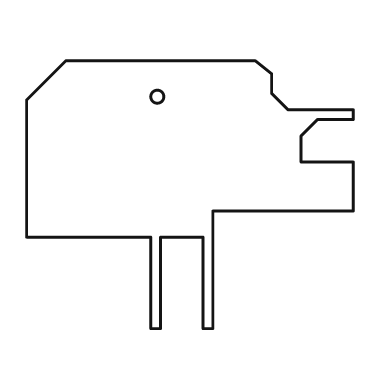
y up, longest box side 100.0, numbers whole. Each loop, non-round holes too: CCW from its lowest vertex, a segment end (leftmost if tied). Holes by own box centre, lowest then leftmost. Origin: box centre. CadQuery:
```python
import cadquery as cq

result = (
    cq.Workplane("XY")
    .moveTo(-12.0, -41.0)
    .lineTo(-9.0, -41.0)
    .lineTo(-9.0, -13.0)
    .lineTo(4.0, -13.0)
    .lineTo(4.0, -41.0)
    .lineTo(7.0, -41.0)
    .lineTo(7.0, -5.0)
    .lineTo(50.0, -5.0)
    .lineTo(50.0, 10.0)
    .lineTo(34.0, 10.0)
    .lineTo(34.0, 18.0)
    .lineTo(39.0, 23.0)
    .lineTo(50.0, 23.0)
    .lineTo(50.0, 26.0)
    .lineTo(30.0, 26.0)
    .lineTo(25.0, 31.0)
    .lineTo(25.0, 37.0)
    .lineTo(20.0, 41.0)
    .lineTo(-38.0, 41.0)
    .lineTo(-50.0, 29.0)
    .lineTo(-50.0, -13.0)
    .lineTo(-12.0, -13.0)
    .close()
    .moveTo(-10.0, 30.0)
    .circle(2.0)
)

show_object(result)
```